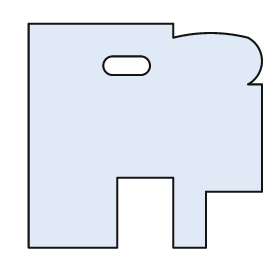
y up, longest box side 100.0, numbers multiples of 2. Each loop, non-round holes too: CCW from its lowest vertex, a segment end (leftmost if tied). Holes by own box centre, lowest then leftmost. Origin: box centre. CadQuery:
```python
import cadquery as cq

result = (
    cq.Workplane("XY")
    .moveTo(-50.0, -48.0)
    .lineTo(-12.0, -48.0)
    .lineTo(-12.0, -18.0)
    .lineTo(12.0, -18.0)
    .lineTo(12.0, -48.0)
    .lineTo(26.0, -48.0)
    .lineTo(26.0, -24.0)
    .lineTo(50.0, -24.0)
    .lineTo(50.0, 22.0)
    .lineTo(44.0, 22.0)
    .threePointArc((50.0, 32.0), (44.0, 42.0))
    .threePointArc((28.0, 44.0), (12.0, 42.0))
    .lineTo(12.0, 48.0)
    .lineTo(-50.0, 48.0)
    .close()
    .moveTo(-14.0, 26.0)
    .lineTo(-2.0, 26.0)
    .threePointArc((2.0, 30.0), (-2.0, 34.0))
    .lineTo(-14.0, 34.0)
    .threePointArc((-18.0, 30.0), (-14.0, 26.0))
    .close()
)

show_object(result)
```